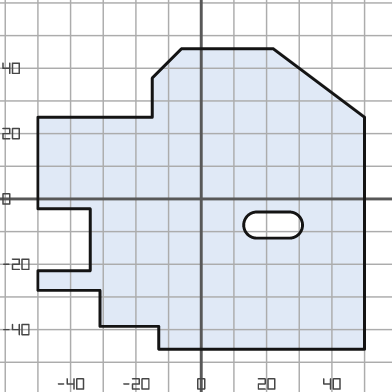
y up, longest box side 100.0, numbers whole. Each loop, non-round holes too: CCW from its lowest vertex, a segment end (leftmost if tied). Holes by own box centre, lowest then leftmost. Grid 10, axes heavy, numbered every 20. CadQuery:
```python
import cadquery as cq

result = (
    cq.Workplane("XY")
    .moveTo(-13.0, -46.0)
    .lineTo(50.0, -46.0)
    .lineTo(50.0, 25.0)
    .lineTo(22.0, 46.0)
    .lineTo(-6.0, 46.0)
    .lineTo(-15.0, 37.0)
    .lineTo(-15.0, 25.0)
    .lineTo(-50.0, 25.0)
    .lineTo(-50.0, -3.0)
    .lineTo(-34.0, -3.0)
    .lineTo(-34.0, -22.0)
    .lineTo(-50.0, -22.0)
    .lineTo(-50.0, -28.0)
    .lineTo(-31.0, -28.0)
    .lineTo(-31.0, -39.0)
    .lineTo(-13.0, -39.0)
    .close()
    .moveTo(17.0, -12.0)
    .lineTo(27.0, -12.0)
    .threePointArc((31.0, -8.0), (27.0, -4.0))
    .lineTo(17.0, -4.0)
    .threePointArc((13.0, -8.0), (17.0, -12.0))
    .close()
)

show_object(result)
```